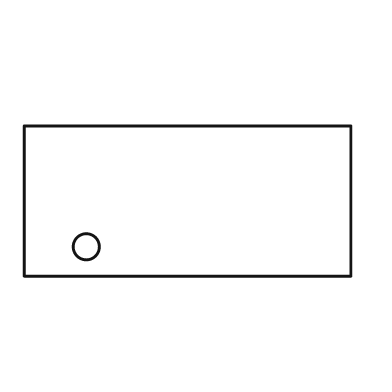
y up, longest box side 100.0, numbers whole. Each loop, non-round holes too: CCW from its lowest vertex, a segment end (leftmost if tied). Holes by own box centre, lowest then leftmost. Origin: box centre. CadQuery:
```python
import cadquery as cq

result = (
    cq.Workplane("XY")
    .moveTo(-50.0, -23.0)
    .lineTo(50.0, -23.0)
    .lineTo(50.0, 23.0)
    .lineTo(-50.0, 23.0)
    .close()
    .moveTo(-31.0, -14.0)
    .circle(4.0)
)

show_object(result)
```